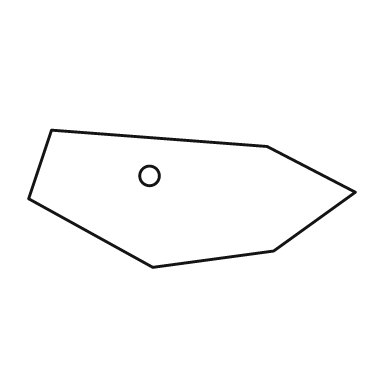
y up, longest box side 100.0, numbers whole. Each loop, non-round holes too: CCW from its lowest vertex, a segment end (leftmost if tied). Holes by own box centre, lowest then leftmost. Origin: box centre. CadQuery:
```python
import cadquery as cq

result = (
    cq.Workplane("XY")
    .moveTo(-12.0, -21.0)
    .lineTo(25.0, -16.0)
    .lineTo(50.0, 2.0)
    .lineTo(23.0, 16.0)
    .lineTo(-43.0, 21.0)
    .lineTo(-50.0, 0.0)
    .close()
    .moveTo(-13.0, 7.0)
    .circle(3.0)
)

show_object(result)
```